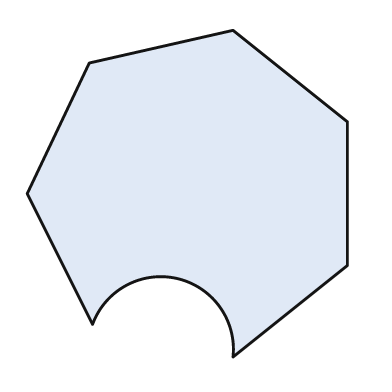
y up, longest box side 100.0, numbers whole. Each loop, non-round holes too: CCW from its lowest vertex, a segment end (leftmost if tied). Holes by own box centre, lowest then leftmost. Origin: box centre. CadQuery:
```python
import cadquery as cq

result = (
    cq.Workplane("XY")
    .moveTo(14.0, -50.0)
    .lineTo(49.0, -22.0)
    .lineTo(49.0, 22.0)
    .lineTo(14.0, 50.0)
    .lineTo(-30.0, 40.0)
    .lineTo(-49.0, 0.0)
    .lineTo(-29.0, -40.0)
    .threePointArc((-3.0, -26.0), (14.0, -50.0))
    .close()
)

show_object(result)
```